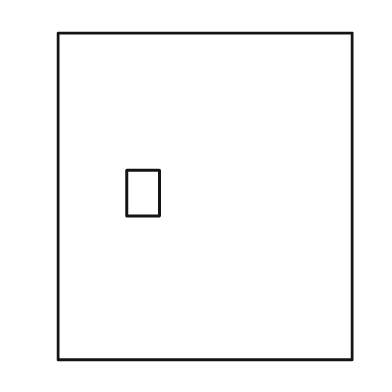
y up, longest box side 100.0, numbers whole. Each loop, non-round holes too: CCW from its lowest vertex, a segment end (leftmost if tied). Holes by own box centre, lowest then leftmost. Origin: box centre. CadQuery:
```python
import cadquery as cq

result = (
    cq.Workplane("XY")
    .moveTo(-45.0, -50.0)
    .lineTo(45.0, -50.0)
    .lineTo(45.0, 50.0)
    .lineTo(-45.0, 50.0)
    .close()
    .moveTo(-24.0, -6.0)
    .lineTo(-14.0, -6.0)
    .lineTo(-14.0, 8.0)
    .lineTo(-24.0, 8.0)
    .close()
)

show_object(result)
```